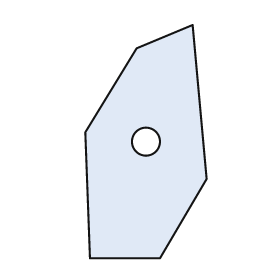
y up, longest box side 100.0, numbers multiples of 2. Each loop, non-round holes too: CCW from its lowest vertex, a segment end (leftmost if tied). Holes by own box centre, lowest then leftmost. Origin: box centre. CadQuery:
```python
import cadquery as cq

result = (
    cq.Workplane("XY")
    .moveTo(-24.0, -50.0)
    .lineTo(6.0, -50.0)
    .lineTo(26.0, -16.0)
    .lineTo(20.0, 50.0)
    .lineTo(-4.0, 40.0)
    .lineTo(-26.0, 4.0)
    .close()
    .moveTo(0.0, 0.0)
    .circle(6.0)
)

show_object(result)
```